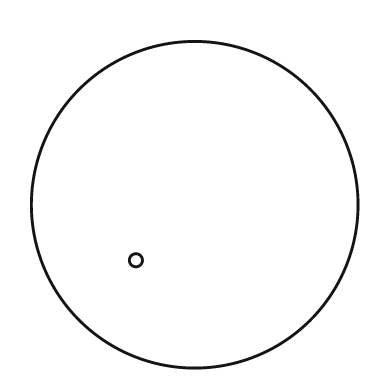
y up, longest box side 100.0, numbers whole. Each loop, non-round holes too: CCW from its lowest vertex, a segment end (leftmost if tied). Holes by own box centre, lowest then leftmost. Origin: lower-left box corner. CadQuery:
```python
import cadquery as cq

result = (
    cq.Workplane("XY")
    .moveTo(50.0, 50.0)
    .circle(50.0)
    .moveTo(32.0, 33.0)
    .circle(2.0)
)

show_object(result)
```